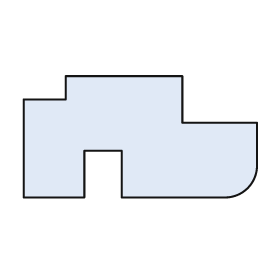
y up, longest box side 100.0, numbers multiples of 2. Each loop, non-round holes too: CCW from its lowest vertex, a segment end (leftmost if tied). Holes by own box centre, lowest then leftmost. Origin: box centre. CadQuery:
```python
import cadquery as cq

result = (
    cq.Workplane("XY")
    .moveTo(-50.0, -26.0)
    .lineTo(-24.0, -26.0)
    .lineTo(-24.0, -6.0)
    .lineTo(-8.0, -6.0)
    .lineTo(-8.0, -26.0)
    .lineTo(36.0, -26.0)
    .threePointArc((46.0, -22.0), (50.0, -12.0))
    .lineTo(50.0, 6.0)
    .lineTo(18.0, 6.0)
    .lineTo(18.0, 26.0)
    .lineTo(-32.0, 26.0)
    .lineTo(-32.0, 16.0)
    .lineTo(-50.0, 16.0)
    .close()
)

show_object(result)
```